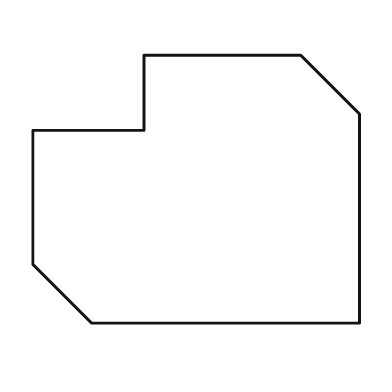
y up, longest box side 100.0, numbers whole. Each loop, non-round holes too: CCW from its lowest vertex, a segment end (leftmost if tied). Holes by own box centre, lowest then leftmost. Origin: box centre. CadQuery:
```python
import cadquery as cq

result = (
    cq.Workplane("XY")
    .moveTo(-32.0, -41.0)
    .lineTo(50.0, -41.0)
    .lineTo(50.0, 23.0)
    .lineTo(32.0, 41.0)
    .lineTo(-16.0, 41.0)
    .lineTo(-16.0, 18.0)
    .lineTo(-50.0, 18.0)
    .lineTo(-50.0, -23.0)
    .close()
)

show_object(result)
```